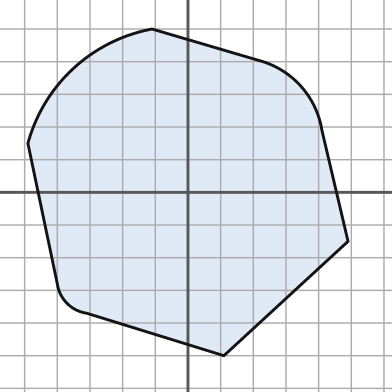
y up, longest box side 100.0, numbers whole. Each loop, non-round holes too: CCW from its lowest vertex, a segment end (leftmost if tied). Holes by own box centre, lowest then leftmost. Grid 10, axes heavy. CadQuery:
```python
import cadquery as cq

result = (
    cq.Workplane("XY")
    .moveTo(11.0, -50.0)
    .lineTo(49.0, -15.0)
    .lineTo(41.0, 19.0)
    .threePointArc((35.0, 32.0), (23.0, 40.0))
    .lineTo(-11.0, 50.0)
    .threePointArc((-35.0, 38.0), (-49.0, 15.0))
    .lineTo(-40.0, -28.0)
    .threePointArc((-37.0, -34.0), (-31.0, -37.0))
    .close()
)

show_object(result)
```